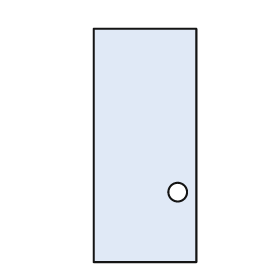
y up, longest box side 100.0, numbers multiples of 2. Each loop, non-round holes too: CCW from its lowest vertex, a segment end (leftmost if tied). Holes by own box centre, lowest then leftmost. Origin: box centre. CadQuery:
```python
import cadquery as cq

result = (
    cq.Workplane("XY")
    .moveTo(-22.0, -50.0)
    .lineTo(22.0, -50.0)
    .lineTo(22.0, 50.0)
    .lineTo(-22.0, 50.0)
    .close()
    .moveTo(14.0, -20.0)
    .circle(4.0)
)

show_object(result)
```